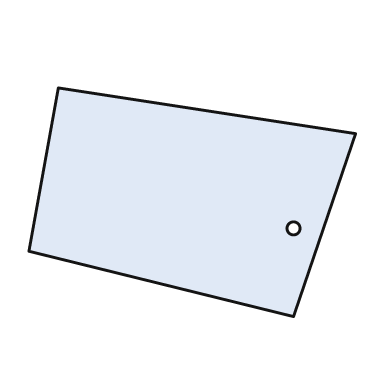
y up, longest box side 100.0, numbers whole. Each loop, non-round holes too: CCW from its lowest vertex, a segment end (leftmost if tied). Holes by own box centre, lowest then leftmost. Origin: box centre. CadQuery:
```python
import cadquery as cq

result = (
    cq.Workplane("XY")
    .moveTo(31.0, -35.0)
    .lineTo(50.0, 21.0)
    .lineTo(-41.0, 35.0)
    .lineTo(-50.0, -15.0)
    .close()
    .moveTo(31.0, -8.0)
    .circle(2.0)
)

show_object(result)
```